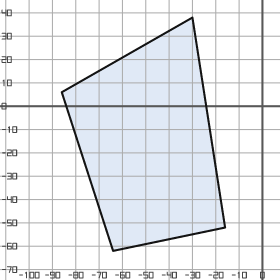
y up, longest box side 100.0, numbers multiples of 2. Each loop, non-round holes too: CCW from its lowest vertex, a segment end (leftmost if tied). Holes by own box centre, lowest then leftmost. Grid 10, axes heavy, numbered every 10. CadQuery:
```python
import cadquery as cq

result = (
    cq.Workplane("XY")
    .moveTo(-64.0, -62.0)
    .lineTo(-16.0, -52.0)
    .lineTo(-30.0, 38.0)
    .lineTo(-86.0, 6.0)
    .close()
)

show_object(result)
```